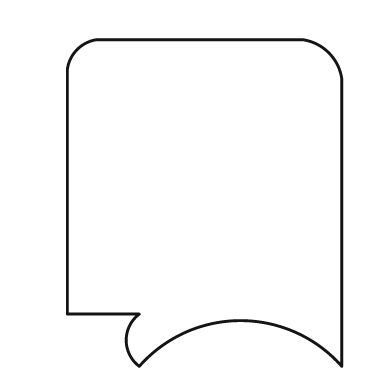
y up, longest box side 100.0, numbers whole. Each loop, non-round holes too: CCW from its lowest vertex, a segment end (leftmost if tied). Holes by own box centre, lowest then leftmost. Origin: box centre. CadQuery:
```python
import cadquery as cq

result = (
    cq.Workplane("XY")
    .moveTo(-20.0, -50.0)
    .threePointArc((11.0, -36.0), (42.0, -50.0))
    .lineTo(42.0, 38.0)
    .threePointArc((38.0, 46.0), (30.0, 50.0))
    .lineTo(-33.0, 50.0)
    .threePointArc((-39.0, 47.0), (-42.0, 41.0))
    .lineTo(-42.0, -34.0)
    .lineTo(-20.0, -34.0)
    .threePointArc((-24.0, -42.0), (-20.0, -50.0))
    .close()
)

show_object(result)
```